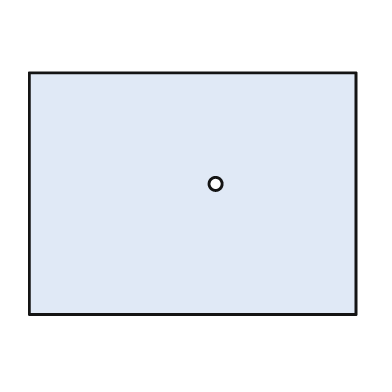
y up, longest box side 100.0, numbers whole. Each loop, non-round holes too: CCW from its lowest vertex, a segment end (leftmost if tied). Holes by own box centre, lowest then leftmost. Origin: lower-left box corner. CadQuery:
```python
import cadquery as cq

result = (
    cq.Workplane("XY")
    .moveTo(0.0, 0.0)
    .lineTo(100.0, 0.0)
    .lineTo(100.0, 74.0)
    .lineTo(0.0, 74.0)
    .close()
    .moveTo(57.0, 40.0)
    .circle(2.0)
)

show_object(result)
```